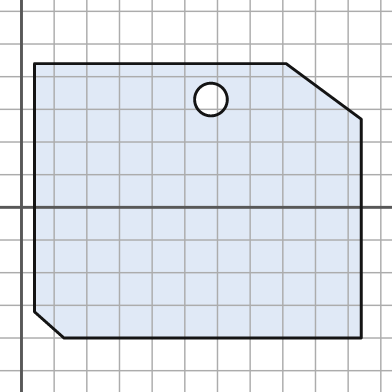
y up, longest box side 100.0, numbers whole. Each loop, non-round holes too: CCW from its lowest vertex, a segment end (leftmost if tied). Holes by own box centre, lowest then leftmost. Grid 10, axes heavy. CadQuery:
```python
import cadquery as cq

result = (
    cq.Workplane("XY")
    .moveTo(13.0, -40.0)
    .lineTo(104.0, -40.0)
    .lineTo(104.0, 27.0)
    .lineTo(81.0, 44.0)
    .lineTo(4.0, 44.0)
    .lineTo(4.0, -32.0)
    .close()
    .moveTo(58.0, 33.0)
    .circle(5.0)
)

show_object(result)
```